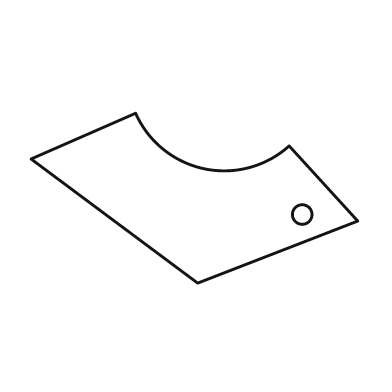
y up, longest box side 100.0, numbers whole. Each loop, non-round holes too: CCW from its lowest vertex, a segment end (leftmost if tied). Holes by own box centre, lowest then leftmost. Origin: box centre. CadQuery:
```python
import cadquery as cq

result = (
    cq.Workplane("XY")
    .moveTo(1.0, -26.0)
    .lineTo(50.0, -7.0)
    .lineTo(29.0, 16.0)
    .threePointArc((3.0, 9.0), (-18.0, 26.0))
    .lineTo(-50.0, 12.0)
    .close()
    .moveTo(33.0, -5.0)
    .circle(3.0)
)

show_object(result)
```